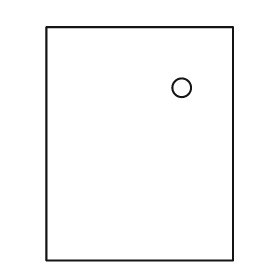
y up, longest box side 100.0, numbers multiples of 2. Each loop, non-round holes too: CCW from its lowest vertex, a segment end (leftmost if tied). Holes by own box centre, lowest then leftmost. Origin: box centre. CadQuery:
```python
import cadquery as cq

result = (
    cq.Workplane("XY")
    .moveTo(-40.0, -50.0)
    .lineTo(40.0, -50.0)
    .lineTo(40.0, 50.0)
    .lineTo(-40.0, 50.0)
    .close()
    .moveTo(18.0, 24.0)
    .circle(4.0)
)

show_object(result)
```